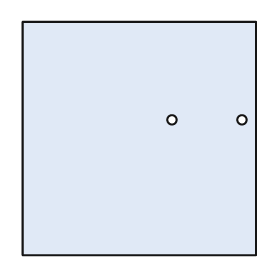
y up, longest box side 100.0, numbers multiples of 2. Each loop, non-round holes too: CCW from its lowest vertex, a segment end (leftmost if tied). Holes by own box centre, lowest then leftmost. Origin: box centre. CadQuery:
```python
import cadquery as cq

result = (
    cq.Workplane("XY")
    .moveTo(-50.0, -50.0)
    .lineTo(50.0, -50.0)
    .lineTo(50.0, 50.0)
    .lineTo(-50.0, 50.0)
    .close()
    .moveTo(14.0, 8.0)
    .circle(2.0)
    .moveTo(44.0, 8.0)
    .circle(2.0)
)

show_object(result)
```